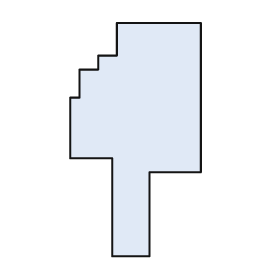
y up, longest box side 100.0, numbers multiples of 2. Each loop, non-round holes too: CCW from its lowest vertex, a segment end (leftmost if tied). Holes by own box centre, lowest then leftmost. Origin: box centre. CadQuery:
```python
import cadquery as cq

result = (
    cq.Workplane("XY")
    .moveTo(-10.0, -50.0)
    .lineTo(6.0, -50.0)
    .lineTo(6.0, -14.0)
    .lineTo(28.0, -14.0)
    .lineTo(28.0, 50.0)
    .lineTo(-8.0, 50.0)
    .lineTo(-8.0, 36.0)
    .lineTo(-16.0, 36.0)
    .lineTo(-16.0, 30.0)
    .lineTo(-24.0, 30.0)
    .lineTo(-24.0, 18.0)
    .lineTo(-28.0, 18.0)
    .lineTo(-28.0, -8.0)
    .lineTo(-10.0, -8.0)
    .close()
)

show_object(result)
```